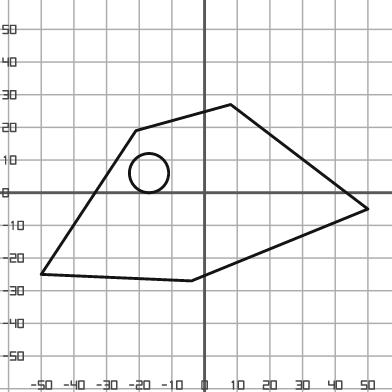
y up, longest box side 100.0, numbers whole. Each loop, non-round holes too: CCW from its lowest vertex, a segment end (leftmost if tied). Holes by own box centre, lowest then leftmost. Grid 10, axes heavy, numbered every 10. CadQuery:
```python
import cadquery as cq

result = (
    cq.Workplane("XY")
    .moveTo(-4.0, -27.0)
    .lineTo(50.0, -5.0)
    .lineTo(8.0, 27.0)
    .lineTo(-21.0, 19.0)
    .lineTo(-50.0, -25.0)
    .close()
    .moveTo(-17.0, 6.0)
    .circle(6.0)
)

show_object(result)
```